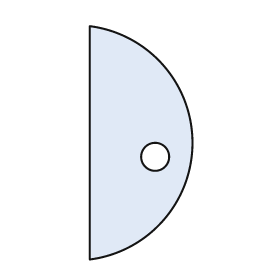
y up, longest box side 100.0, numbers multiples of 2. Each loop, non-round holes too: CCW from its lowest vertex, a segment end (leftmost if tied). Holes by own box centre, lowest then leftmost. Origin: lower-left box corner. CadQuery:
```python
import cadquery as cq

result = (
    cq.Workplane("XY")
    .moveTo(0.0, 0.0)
    .threePointArc((44.0, 50.0), (0.0, 100.0))
    .close()
    .moveTo(28.0, 44.0)
    .circle(6.0)
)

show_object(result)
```